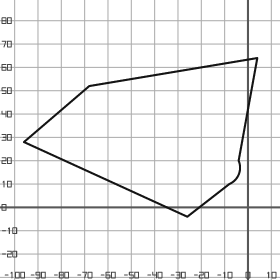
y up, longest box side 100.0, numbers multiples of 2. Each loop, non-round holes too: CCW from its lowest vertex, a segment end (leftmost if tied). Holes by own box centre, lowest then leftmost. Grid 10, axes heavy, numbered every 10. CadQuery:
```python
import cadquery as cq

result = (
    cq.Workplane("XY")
    .moveTo(-26.0, -4.0)
    .lineTo(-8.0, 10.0)
    .threePointArc((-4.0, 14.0), (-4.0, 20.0))
    .lineTo(4.0, 64.0)
    .lineTo(-68.0, 52.0)
    .lineTo(-96.0, 28.0)
    .close()
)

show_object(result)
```